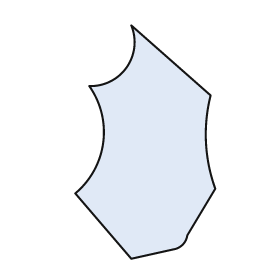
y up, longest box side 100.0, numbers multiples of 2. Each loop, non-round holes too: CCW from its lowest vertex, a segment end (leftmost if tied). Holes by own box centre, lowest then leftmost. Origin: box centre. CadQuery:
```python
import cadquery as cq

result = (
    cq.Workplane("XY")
    .moveTo(-6.0, -50.0)
    .lineTo(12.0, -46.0)
    .threePointArc((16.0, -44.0), (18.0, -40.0))
    .lineTo(30.0, -20.0)
    .threePointArc((26.0, 0.0), (28.0, 20.0))
    .lineTo(-6.0, 50.0)
    .threePointArc((-8.0, 32.0), (-24.0, 24.0))
    .threePointArc((-18.0, 0.0), (-30.0, -22.0))
    .close()
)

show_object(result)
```